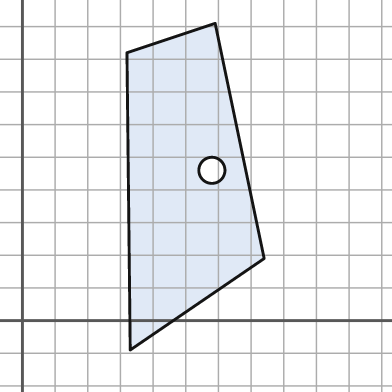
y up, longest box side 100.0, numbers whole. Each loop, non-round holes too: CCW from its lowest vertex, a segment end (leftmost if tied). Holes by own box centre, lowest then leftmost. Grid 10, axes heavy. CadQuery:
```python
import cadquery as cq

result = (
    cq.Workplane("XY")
    .moveTo(33.0, -9.0)
    .lineTo(74.0, 19.0)
    .lineTo(59.0, 91.0)
    .lineTo(32.0, 82.0)
    .close()
    .moveTo(58.0, 46.0)
    .circle(4.0)
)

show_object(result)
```